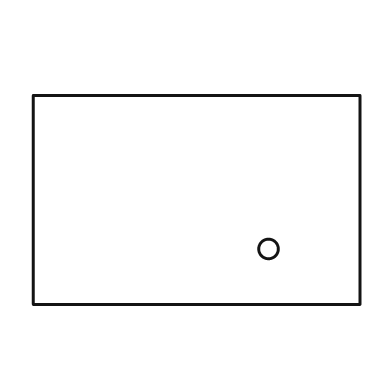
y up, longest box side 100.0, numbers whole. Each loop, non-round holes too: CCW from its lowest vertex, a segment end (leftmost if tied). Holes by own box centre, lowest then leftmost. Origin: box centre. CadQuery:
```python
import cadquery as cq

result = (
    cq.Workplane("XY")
    .moveTo(-50.0, -32.0)
    .lineTo(50.0, -32.0)
    .lineTo(50.0, 32.0)
    .lineTo(-50.0, 32.0)
    .close()
    .moveTo(22.0, -15.0)
    .circle(3.0)
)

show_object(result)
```